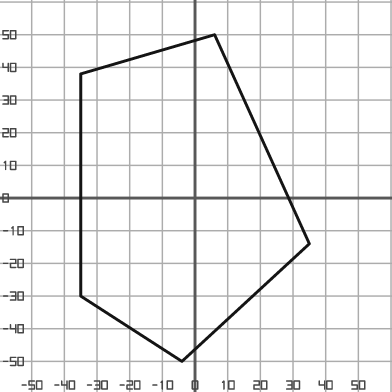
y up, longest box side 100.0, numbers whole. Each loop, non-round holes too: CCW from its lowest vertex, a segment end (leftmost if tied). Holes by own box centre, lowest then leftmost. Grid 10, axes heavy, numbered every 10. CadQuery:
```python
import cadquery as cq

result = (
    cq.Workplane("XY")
    .moveTo(-4.0, -50.0)
    .lineTo(35.0, -14.0)
    .lineTo(6.0, 50.0)
    .lineTo(-35.0, 38.0)
    .lineTo(-35.0, -30.0)
    .close()
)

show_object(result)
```